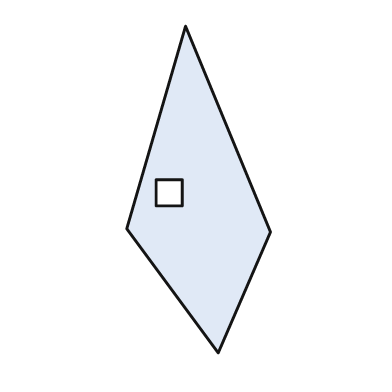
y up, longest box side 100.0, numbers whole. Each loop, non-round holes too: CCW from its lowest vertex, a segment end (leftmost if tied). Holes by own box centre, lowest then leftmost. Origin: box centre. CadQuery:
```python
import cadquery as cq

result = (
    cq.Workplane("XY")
    .moveTo(6.0, -50.0)
    .lineTo(22.0, -13.0)
    .lineTo(-4.0, 50.0)
    .lineTo(-22.0, -12.0)
    .close()
    .moveTo(-13.0, -5.0)
    .lineTo(-5.0, -5.0)
    .lineTo(-5.0, 3.0)
    .lineTo(-13.0, 3.0)
    .close()
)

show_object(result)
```